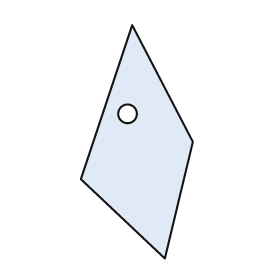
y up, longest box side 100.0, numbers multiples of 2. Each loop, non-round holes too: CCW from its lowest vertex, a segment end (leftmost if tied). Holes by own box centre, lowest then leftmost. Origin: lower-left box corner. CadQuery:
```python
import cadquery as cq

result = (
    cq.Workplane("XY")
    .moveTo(36.0, 0.0)
    .lineTo(48.0, 50.0)
    .lineTo(22.0, 100.0)
    .lineTo(0.0, 34.0)
    .close()
    .moveTo(20.0, 62.0)
    .circle(4.0)
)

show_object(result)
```